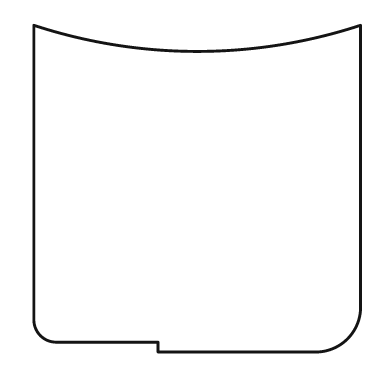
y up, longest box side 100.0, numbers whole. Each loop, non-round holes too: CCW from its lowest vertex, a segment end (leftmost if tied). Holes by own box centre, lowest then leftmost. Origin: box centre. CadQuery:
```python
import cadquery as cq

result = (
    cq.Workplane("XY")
    .moveTo(-12.0, -50.0)
    .lineTo(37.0, -50.0)
    .threePointArc((46.0, -46.0), (50.0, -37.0))
    .lineTo(50.0, 50.0)
    .threePointArc((0.0, 42.0), (-50.0, 50.0))
    .lineTo(-50.0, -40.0)
    .threePointArc((-48.0, -45.0), (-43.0, -47.0))
    .lineTo(-12.0, -47.0)
    .close()
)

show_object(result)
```